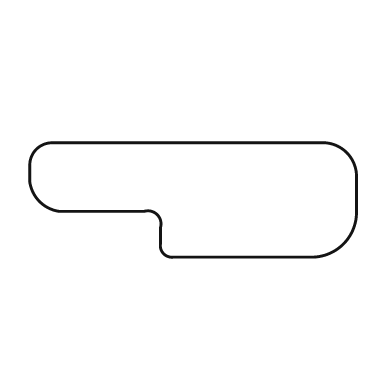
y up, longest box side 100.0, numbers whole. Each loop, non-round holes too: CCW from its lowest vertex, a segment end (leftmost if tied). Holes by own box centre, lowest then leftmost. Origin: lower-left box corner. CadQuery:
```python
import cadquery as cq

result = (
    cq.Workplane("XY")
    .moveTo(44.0, 0.0)
    .lineTo(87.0, 0.0)
    .threePointArc((96.0, 4.0), (100.0, 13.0))
    .lineTo(100.0, 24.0)
    .threePointArc((97.0, 32.0), (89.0, 35.0))
    .lineTo(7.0, 35.0)
    .threePointArc((2.0, 33.0), (0.0, 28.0))
    .lineTo(0.0, 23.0)
    .threePointArc((3.0, 17.0), (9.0, 14.0))
    .lineTo(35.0, 14.0)
    .threePointArc((39.0, 13.0), (40.0, 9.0))
    .lineTo(40.0, 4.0)
    .threePointArc((41.0, 1.0), (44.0, 0.0))
    .close()
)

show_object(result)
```